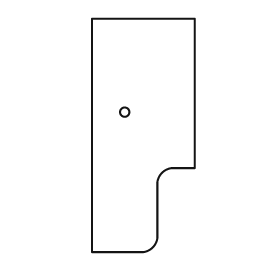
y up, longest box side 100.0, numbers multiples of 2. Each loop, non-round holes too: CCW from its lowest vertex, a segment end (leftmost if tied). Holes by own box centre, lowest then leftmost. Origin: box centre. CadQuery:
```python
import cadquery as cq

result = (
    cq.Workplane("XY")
    .moveTo(-22.0, -50.0)
    .lineTo(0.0, -50.0)
    .threePointArc((4.0, -48.0), (6.0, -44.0))
    .lineTo(6.0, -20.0)
    .threePointArc((8.0, -16.0), (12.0, -14.0))
    .lineTo(22.0, -14.0)
    .lineTo(22.0, 50.0)
    .lineTo(-22.0, 50.0)
    .close()
    .moveTo(-8.0, 10.0)
    .circle(2.0)
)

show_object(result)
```